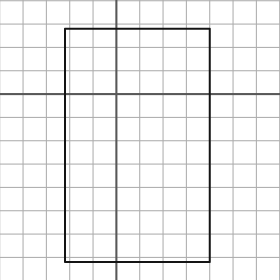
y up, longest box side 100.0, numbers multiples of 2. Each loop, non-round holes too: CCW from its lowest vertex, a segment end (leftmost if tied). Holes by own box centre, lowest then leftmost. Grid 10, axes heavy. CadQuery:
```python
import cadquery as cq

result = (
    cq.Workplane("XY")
    .moveTo(-22.0, -72.0)
    .lineTo(40.0, -72.0)
    .lineTo(40.0, 28.0)
    .lineTo(-22.0, 28.0)
    .close()
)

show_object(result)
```